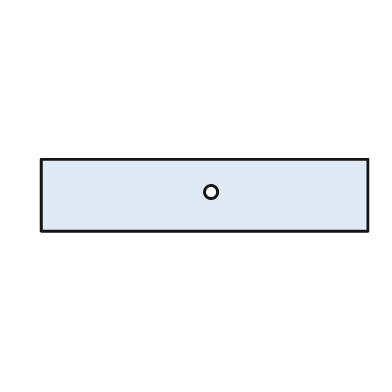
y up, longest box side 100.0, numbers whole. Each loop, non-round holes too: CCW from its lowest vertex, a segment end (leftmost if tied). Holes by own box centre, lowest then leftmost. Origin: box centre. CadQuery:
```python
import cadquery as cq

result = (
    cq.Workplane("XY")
    .moveTo(-50.0, -11.0)
    .lineTo(50.0, -11.0)
    .lineTo(50.0, 11.0)
    .lineTo(-50.0, 11.0)
    .close()
    .moveTo(2.0, 1.0)
    .circle(2.0)
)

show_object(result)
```